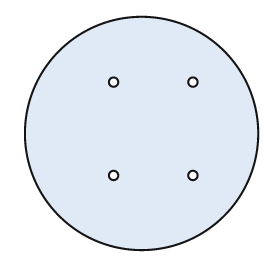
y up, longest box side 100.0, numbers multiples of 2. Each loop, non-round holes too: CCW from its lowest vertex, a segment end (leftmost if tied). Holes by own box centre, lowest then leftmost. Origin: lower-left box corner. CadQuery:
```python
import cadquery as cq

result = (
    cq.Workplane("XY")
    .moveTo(50.0, 50.0)
    .circle(50.0)
    .moveTo(38.0, 32.0)
    .circle(2.0)
    .moveTo(72.0, 32.0)
    .circle(2.0)
    .moveTo(38.0, 72.0)
    .circle(2.0)
    .moveTo(72.0, 72.0)
    .circle(2.0)
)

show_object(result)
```